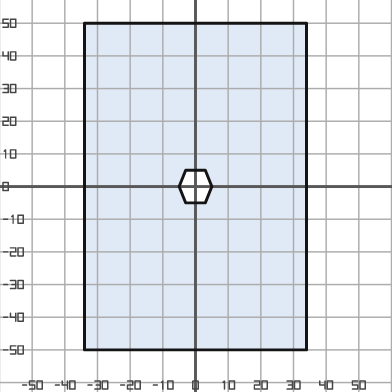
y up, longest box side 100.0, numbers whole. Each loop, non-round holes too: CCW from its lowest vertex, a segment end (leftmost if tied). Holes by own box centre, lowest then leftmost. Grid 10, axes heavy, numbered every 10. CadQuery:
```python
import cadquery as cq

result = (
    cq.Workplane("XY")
    .moveTo(-34.0, -50.0)
    .lineTo(34.0, -50.0)
    .lineTo(34.0, 50.0)
    .lineTo(-34.0, 50.0)
    .close()
    .moveTo(-3.0, -5.0)
    .lineTo(3.0, -5.0)
    .lineTo(5.0, 0.0)
    .lineTo(3.0, 5.0)
    .lineTo(-3.0, 5.0)
    .lineTo(-5.0, 0.0)
    .close()
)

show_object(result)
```